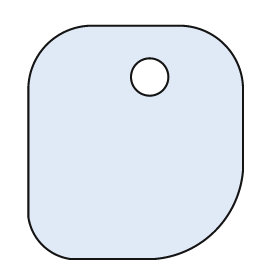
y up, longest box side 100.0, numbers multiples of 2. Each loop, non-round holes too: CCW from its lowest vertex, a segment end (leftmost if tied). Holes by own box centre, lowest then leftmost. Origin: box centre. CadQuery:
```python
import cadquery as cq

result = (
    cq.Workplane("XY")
    .moveTo(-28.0, -50.0)
    .lineTo(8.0, -50.0)
    .threePointArc((34.0, -38.0), (46.0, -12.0))
    .lineTo(46.0, 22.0)
    .threePointArc((38.0, 42.0), (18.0, 50.0))
    .lineTo(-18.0, 50.0)
    .threePointArc((-38.0, 42.0), (-46.0, 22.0))
    .lineTo(-46.0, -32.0)
    .threePointArc((-40.0, -44.0), (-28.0, -50.0))
    .close()
    .moveTo(6.0, 28.0)
    .circle(8.0)
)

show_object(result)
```